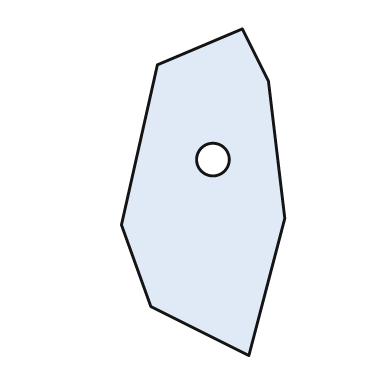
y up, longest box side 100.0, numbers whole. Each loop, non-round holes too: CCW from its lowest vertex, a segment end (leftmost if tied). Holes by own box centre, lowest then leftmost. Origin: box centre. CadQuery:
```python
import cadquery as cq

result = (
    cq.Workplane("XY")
    .moveTo(14.0, -50.0)
    .lineTo(25.0, -8.0)
    .lineTo(20.0, 34.0)
    .lineTo(12.0, 50.0)
    .lineTo(-14.0, 39.0)
    .lineTo(-25.0, -10.0)
    .lineTo(-16.0, -35.0)
    .close()
    .moveTo(3.0, 10.0)
    .circle(5.0)
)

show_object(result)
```